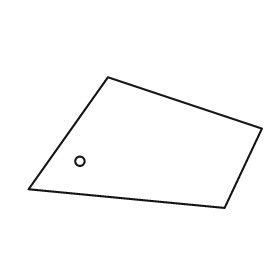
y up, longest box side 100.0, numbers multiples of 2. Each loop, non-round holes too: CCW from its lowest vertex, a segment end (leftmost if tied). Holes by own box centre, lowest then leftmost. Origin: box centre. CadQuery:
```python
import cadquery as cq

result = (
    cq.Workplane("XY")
    .moveTo(34.0, -28.0)
    .lineTo(50.0, 6.0)
    .lineTo(-16.0, 28.0)
    .lineTo(-50.0, -20.0)
    .close()
    .moveTo(-28.0, -8.0)
    .circle(2.0)
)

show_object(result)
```